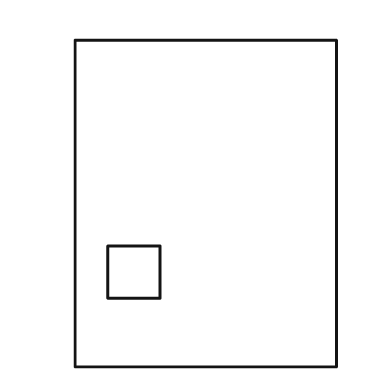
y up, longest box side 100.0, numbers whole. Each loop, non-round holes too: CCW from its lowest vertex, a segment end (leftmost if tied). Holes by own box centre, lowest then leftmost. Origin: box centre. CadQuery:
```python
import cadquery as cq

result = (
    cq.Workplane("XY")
    .moveTo(-40.0, -50.0)
    .lineTo(40.0, -50.0)
    .lineTo(40.0, 50.0)
    .lineTo(-40.0, 50.0)
    .close()
    .moveTo(-30.0, -29.0)
    .lineTo(-14.0, -29.0)
    .lineTo(-14.0, -13.0)
    .lineTo(-30.0, -13.0)
    .close()
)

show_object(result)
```